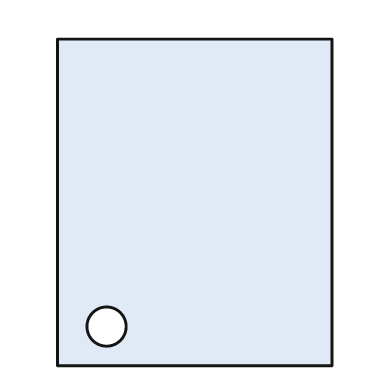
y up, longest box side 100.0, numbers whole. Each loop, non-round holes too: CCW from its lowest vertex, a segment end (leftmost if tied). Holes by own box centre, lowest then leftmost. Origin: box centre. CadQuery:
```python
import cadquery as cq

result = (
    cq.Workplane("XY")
    .moveTo(-42.0, -50.0)
    .lineTo(42.0, -50.0)
    .lineTo(42.0, 50.0)
    .lineTo(-42.0, 50.0)
    .close()
    .moveTo(-27.0, -38.0)
    .circle(6.0)
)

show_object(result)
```